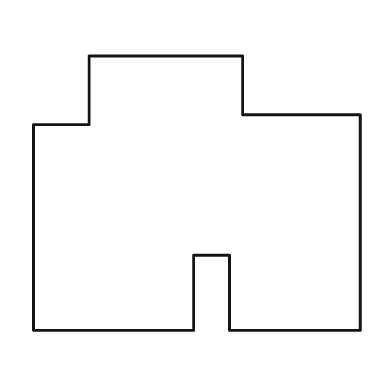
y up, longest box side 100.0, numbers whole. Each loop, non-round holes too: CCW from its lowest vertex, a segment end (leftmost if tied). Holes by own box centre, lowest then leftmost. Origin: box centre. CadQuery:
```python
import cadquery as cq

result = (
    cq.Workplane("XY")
    .moveTo(-50.0, -42.0)
    .lineTo(-1.0, -42.0)
    .lineTo(-1.0, -19.0)
    .lineTo(10.0, -19.0)
    .lineTo(10.0, -42.0)
    .lineTo(50.0, -42.0)
    .lineTo(50.0, 24.0)
    .lineTo(14.0, 24.0)
    .lineTo(14.0, 42.0)
    .lineTo(-33.0, 42.0)
    .lineTo(-33.0, 21.0)
    .lineTo(-50.0, 21.0)
    .close()
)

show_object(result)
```